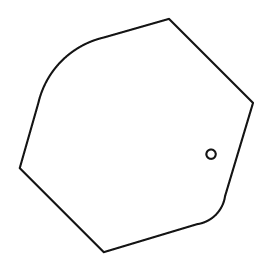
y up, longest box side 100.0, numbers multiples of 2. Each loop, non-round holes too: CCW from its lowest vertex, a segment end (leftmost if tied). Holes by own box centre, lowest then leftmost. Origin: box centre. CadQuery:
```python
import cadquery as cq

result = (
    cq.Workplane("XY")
    .moveTo(-14.0, -50.0)
    .lineTo(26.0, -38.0)
    .threePointArc((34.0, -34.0), (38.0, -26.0))
    .lineTo(50.0, 14.0)
    .lineTo(14.0, 50.0)
    .lineTo(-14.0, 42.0)
    .threePointArc((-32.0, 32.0), (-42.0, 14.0))
    .lineTo(-50.0, -14.0)
    .close()
    .moveTo(32.0, -8.0)
    .circle(2.0)
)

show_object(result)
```